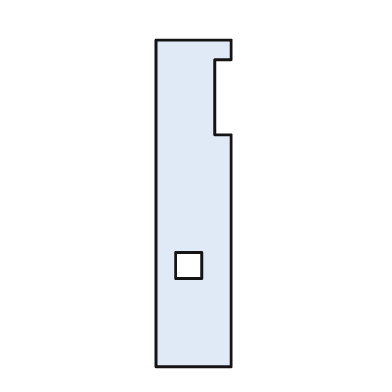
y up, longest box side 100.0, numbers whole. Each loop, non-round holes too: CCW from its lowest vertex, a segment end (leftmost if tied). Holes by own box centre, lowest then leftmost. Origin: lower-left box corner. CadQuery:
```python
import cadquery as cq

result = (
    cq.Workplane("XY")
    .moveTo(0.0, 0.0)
    .lineTo(23.0, 0.0)
    .lineTo(23.0, 71.0)
    .lineTo(18.0, 71.0)
    .lineTo(18.0, 94.0)
    .lineTo(23.0, 94.0)
    .lineTo(23.0, 100.0)
    .lineTo(0.0, 100.0)
    .close()
    .moveTo(6.0, 27.0)
    .lineTo(14.0, 27.0)
    .lineTo(14.0, 35.0)
    .lineTo(6.0, 35.0)
    .close()
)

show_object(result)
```